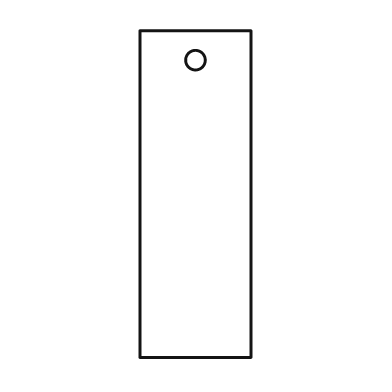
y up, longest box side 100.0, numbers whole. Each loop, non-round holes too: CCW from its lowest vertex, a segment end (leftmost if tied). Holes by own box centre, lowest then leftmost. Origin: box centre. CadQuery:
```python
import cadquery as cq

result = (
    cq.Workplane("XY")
    .moveTo(-17.0, -50.0)
    .lineTo(17.0, -50.0)
    .lineTo(17.0, 50.0)
    .lineTo(-17.0, 50.0)
    .close()
    .moveTo(0.0, 41.0)
    .circle(3.0)
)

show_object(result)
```